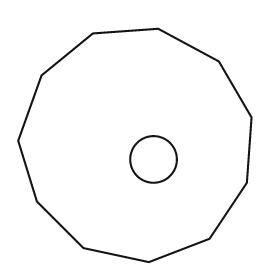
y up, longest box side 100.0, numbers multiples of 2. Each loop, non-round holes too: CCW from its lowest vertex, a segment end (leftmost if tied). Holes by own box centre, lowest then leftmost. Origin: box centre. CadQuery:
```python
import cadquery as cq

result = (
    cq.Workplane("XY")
    .moveTo(6.0, -50.0)
    .lineTo(32.0, -40.0)
    .lineTo(48.0, -16.0)
    .lineTo(50.0, 12.0)
    .lineTo(36.0, 36.0)
    .lineTo(10.0, 50.0)
    .lineTo(-18.0, 48.0)
    .lineTo(-40.0, 30.0)
    .lineTo(-50.0, 2.0)
    .lineTo(-42.0, -24.0)
    .lineTo(-22.0, -44.0)
    .close()
    .moveTo(8.0, -6.0)
    .circle(10.0)
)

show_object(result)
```